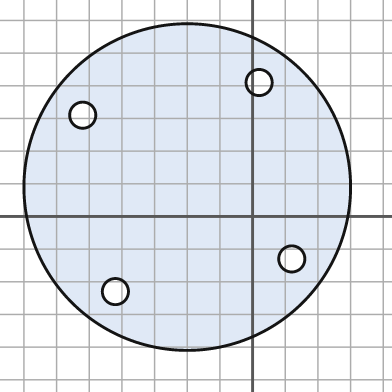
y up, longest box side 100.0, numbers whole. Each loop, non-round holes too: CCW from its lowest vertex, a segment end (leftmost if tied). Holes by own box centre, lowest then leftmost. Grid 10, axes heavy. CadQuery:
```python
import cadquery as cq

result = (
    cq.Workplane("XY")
    .moveTo(-20.0, 9.0)
    .circle(50.0)
    .moveTo(-42.0, -23.0)
    .circle(4.0)
    .moveTo(12.0, -13.0)
    .circle(4.0)
    .moveTo(-52.0, 31.0)
    .circle(4.0)
    .moveTo(2.0, 41.0)
    .circle(4.0)
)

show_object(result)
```